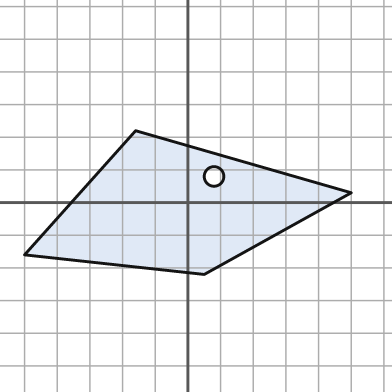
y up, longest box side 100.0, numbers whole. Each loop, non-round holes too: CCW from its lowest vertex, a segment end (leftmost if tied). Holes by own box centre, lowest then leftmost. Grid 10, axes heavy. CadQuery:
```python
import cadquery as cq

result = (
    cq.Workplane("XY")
    .moveTo(5.0, -22.0)
    .lineTo(50.0, 3.0)
    .lineTo(-16.0, 22.0)
    .lineTo(-50.0, -16.0)
    .close()
    .moveTo(8.0, 8.0)
    .circle(3.0)
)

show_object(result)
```